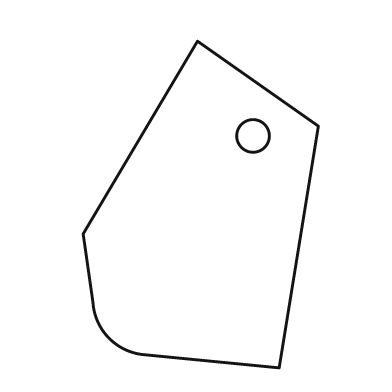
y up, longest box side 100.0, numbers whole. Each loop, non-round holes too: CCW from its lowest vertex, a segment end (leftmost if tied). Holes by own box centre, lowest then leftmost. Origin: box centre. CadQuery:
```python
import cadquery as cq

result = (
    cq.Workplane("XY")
    .moveTo(24.0, -50.0)
    .lineTo(36.0, 24.0)
    .lineTo(-1.0, 50.0)
    .lineTo(-36.0, -9.0)
    .lineTo(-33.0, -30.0)
    .threePointArc((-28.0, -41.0), (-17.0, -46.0))
    .close()
    .moveTo(16.0, 21.0)
    .circle(5.0)
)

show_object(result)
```